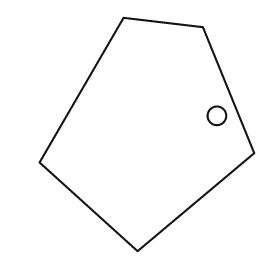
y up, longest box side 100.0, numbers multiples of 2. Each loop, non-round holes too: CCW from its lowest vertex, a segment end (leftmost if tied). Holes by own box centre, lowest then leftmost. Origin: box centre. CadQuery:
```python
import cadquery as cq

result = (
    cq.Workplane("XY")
    .moveTo(-4.0, -50.0)
    .lineTo(46.0, -8.0)
    .lineTo(24.0, 46.0)
    .lineTo(-10.0, 50.0)
    .lineTo(-46.0, -12.0)
    .close()
    .moveTo(30.0, 8.0)
    .circle(4.0)
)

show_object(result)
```